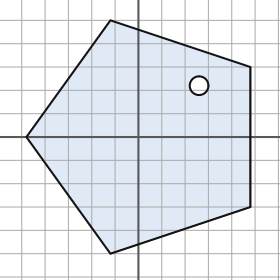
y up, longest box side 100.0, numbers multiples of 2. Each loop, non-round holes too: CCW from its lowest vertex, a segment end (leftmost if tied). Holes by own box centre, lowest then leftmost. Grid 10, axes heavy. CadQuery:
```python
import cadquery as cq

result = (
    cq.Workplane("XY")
    .moveTo(-12.0, -50.0)
    .lineTo(48.0, -30.0)
    .lineTo(48.0, 30.0)
    .lineTo(-12.0, 50.0)
    .lineTo(-48.0, 0.0)
    .close()
    .moveTo(26.0, 22.0)
    .circle(4.0)
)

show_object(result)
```